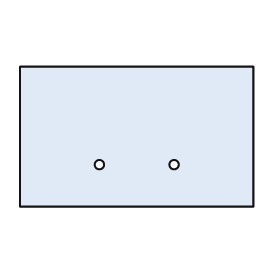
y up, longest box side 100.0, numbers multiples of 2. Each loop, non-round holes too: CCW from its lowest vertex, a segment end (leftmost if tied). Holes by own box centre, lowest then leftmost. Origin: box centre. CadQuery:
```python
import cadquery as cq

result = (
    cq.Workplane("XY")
    .moveTo(-50.0, -30.0)
    .lineTo(50.0, -30.0)
    .lineTo(50.0, 30.0)
    .lineTo(-50.0, 30.0)
    .close()
    .moveTo(-16.0, -12.0)
    .circle(2.0)
    .moveTo(16.0, -12.0)
    .circle(2.0)
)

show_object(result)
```